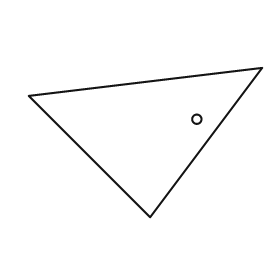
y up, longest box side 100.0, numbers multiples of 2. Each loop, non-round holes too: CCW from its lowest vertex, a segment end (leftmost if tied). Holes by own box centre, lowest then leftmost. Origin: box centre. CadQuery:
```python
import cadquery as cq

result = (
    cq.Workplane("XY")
    .moveTo(2.0, -32.0)
    .lineTo(50.0, 32.0)
    .lineTo(-50.0, 20.0)
    .close()
    .moveTo(22.0, 10.0)
    .circle(2.0)
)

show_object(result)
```